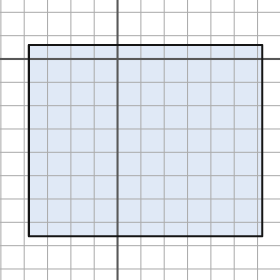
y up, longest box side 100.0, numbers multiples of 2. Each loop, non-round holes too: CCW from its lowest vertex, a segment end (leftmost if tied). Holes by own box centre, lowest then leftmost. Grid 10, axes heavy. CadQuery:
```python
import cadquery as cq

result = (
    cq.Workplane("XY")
    .moveTo(-38.0, -76.0)
    .lineTo(62.0, -76.0)
    .lineTo(62.0, 6.0)
    .lineTo(-38.0, 6.0)
    .close()
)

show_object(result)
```